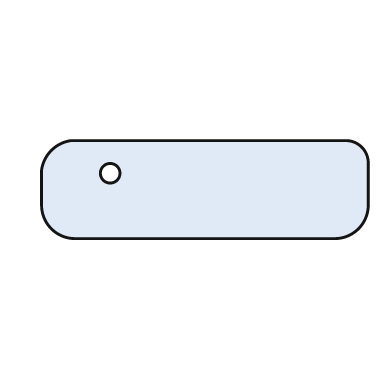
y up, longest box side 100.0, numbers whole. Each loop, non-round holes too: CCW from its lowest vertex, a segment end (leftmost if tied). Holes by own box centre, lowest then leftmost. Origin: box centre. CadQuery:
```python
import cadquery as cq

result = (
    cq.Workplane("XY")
    .moveTo(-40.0, -15.0)
    .lineTo(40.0, -15.0)
    .threePointArc((47.0, -12.0), (50.0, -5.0))
    .lineTo(50.0, 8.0)
    .threePointArc((48.0, 13.0), (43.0, 15.0))
    .lineTo(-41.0, 15.0)
    .threePointArc((-47.0, 12.0), (-50.0, 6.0))
    .lineTo(-50.0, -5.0)
    .threePointArc((-47.0, -12.0), (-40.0, -15.0))
    .close()
    .moveTo(-29.0, 5.0)
    .circle(3.0)
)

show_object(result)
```